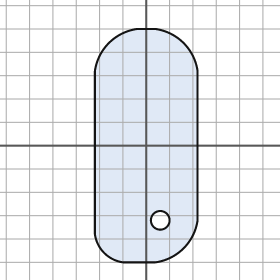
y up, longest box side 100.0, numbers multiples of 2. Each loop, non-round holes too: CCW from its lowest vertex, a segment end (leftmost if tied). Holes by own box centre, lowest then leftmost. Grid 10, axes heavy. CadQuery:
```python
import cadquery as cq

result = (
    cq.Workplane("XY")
    .moveTo(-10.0, -50.0)
    .lineTo(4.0, -50.0)
    .threePointArc((16.0, -44.0), (22.0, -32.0))
    .lineTo(22.0, 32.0)
    .threePointArc((16.0, 44.0), (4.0, 50.0))
    .lineTo(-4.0, 50.0)
    .threePointArc((-16.0, 44.0), (-22.0, 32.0))
    .lineTo(-22.0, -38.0)
    .threePointArc((-18.0, -46.0), (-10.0, -50.0))
    .close()
    .moveTo(6.0, -32.0)
    .circle(4.0)
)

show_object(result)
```